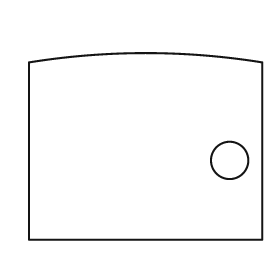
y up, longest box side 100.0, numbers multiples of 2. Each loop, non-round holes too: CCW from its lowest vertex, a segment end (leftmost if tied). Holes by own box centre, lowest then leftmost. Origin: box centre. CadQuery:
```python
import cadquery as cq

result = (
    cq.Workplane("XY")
    .moveTo(-50.0, -40.0)
    .lineTo(50.0, -40.0)
    .lineTo(50.0, 36.0)
    .threePointArc((0.0, 40.0), (-50.0, 36.0))
    .close()
    .moveTo(36.0, -6.0)
    .circle(8.0)
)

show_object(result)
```